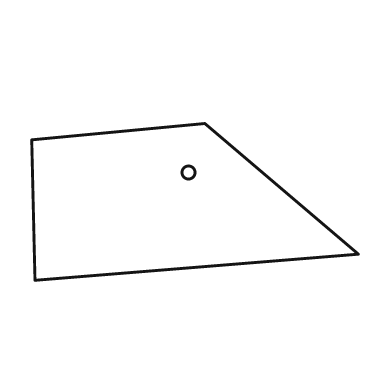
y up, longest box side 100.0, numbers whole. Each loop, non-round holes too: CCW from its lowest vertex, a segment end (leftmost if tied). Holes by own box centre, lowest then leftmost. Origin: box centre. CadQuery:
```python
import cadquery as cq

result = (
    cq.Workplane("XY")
    .moveTo(-49.0, -24.0)
    .lineTo(50.0, -16.0)
    .lineTo(3.0, 24.0)
    .lineTo(-50.0, 19.0)
    .close()
    .moveTo(-2.0, 9.0)
    .circle(2.0)
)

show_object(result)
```